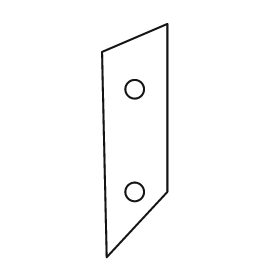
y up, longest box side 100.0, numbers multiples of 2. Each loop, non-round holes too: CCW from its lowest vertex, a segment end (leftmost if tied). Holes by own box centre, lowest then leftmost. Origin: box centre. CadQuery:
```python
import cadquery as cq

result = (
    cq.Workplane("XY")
    .moveTo(-12.0, -50.0)
    .lineTo(14.0, -22.0)
    .lineTo(14.0, 50.0)
    .lineTo(-14.0, 38.0)
    .close()
    .moveTo(0.0, -22.0)
    .circle(4.0)
    .moveTo(0.0, 22.0)
    .circle(4.0)
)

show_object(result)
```